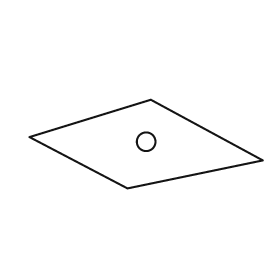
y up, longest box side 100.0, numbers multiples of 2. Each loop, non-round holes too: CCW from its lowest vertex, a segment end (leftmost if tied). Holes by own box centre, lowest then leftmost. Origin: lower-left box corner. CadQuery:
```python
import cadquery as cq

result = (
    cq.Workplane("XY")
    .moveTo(42.0, 0.0)
    .lineTo(100.0, 12.0)
    .lineTo(52.0, 38.0)
    .lineTo(0.0, 22.0)
    .close()
    .moveTo(50.0, 20.0)
    .circle(4.0)
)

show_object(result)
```